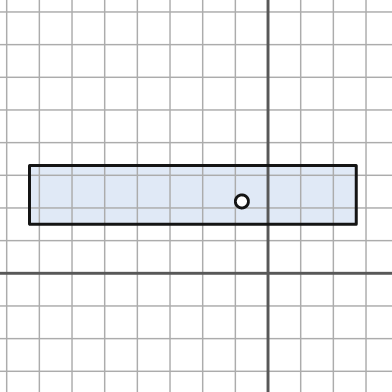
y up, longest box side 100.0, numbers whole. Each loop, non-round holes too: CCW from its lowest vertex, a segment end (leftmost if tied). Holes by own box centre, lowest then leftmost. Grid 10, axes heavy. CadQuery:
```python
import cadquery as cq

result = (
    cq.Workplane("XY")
    .moveTo(-73.0, 15.0)
    .lineTo(27.0, 15.0)
    .lineTo(27.0, 33.0)
    .lineTo(-73.0, 33.0)
    .close()
    .moveTo(-8.0, 22.0)
    .circle(2.0)
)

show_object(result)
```